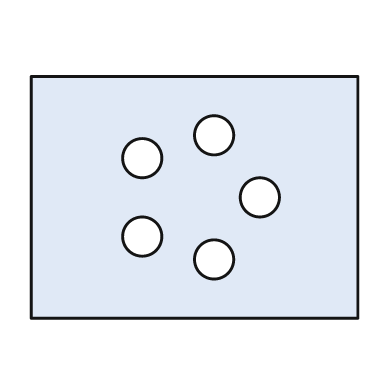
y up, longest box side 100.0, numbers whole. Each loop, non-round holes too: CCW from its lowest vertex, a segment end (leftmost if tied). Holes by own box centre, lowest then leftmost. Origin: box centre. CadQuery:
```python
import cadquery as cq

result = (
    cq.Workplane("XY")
    .moveTo(-50.0, -37.0)
    .lineTo(50.0, -37.0)
    .lineTo(50.0, 37.0)
    .lineTo(-50.0, 37.0)
    .close()
    .moveTo(6.0, -19.0)
    .circle(6.0)
    .moveTo(-16.0, -12.0)
    .circle(6.0)
    .moveTo(20.0, 0.0)
    .circle(6.0)
    .moveTo(-16.0, 12.0)
    .circle(6.0)
    .moveTo(6.0, 19.0)
    .circle(6.0)
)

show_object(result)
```